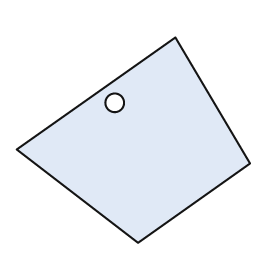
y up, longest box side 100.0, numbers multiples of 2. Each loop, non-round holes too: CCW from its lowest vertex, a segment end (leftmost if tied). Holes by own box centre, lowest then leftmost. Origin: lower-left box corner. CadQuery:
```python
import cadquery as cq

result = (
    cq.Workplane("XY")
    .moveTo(52.0, 0.0)
    .lineTo(100.0, 34.0)
    .lineTo(68.0, 88.0)
    .lineTo(0.0, 40.0)
    .close()
    .moveTo(42.0, 60.0)
    .circle(4.0)
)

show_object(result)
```